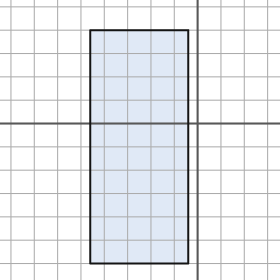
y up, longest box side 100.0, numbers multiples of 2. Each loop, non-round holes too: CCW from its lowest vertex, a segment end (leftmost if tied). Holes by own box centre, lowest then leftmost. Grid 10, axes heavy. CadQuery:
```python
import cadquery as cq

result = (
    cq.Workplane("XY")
    .moveTo(-46.0, -60.0)
    .lineTo(-4.0, -60.0)
    .lineTo(-4.0, 40.0)
    .lineTo(-46.0, 40.0)
    .close()
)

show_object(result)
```